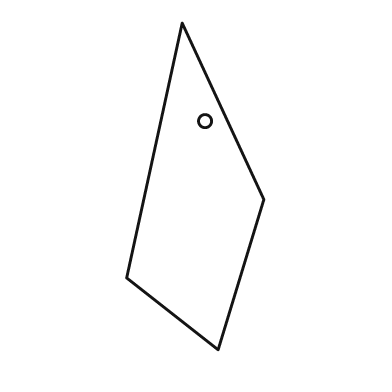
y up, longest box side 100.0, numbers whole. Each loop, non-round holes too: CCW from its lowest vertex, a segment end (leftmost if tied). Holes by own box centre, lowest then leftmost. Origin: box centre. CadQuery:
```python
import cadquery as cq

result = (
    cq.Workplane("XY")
    .moveTo(7.0, -50.0)
    .lineTo(21.0, -4.0)
    .lineTo(-4.0, 50.0)
    .lineTo(-21.0, -28.0)
    .close()
    .moveTo(3.0, 20.0)
    .circle(2.0)
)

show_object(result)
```